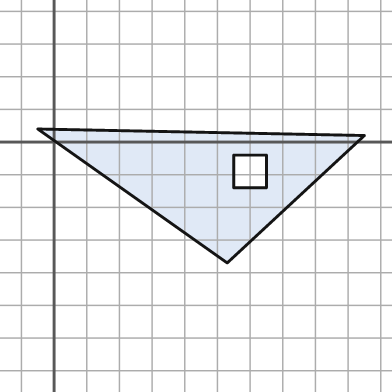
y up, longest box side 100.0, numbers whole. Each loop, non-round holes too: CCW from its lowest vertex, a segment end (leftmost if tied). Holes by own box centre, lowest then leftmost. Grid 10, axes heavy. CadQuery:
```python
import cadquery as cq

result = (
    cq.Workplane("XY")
    .moveTo(53.0, -37.0)
    .lineTo(95.0, 2.0)
    .lineTo(-5.0, 4.0)
    .close()
    .moveTo(55.0, -14.0)
    .lineTo(65.0, -14.0)
    .lineTo(65.0, -4.0)
    .lineTo(55.0, -4.0)
    .close()
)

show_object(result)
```